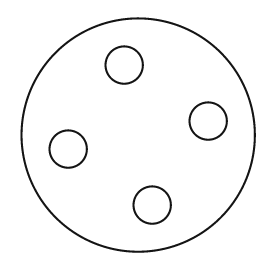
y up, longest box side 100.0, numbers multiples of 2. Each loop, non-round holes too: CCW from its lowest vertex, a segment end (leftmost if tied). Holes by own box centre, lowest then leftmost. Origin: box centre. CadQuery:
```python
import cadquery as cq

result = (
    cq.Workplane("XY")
    .moveTo(0.0, 0.0)
    .circle(50.0)
    .moveTo(6.0, -30.0)
    .circle(8.0)
    .moveTo(-30.0, -6.0)
    .circle(8.0)
    .moveTo(30.0, 6.0)
    .circle(8.0)
    .moveTo(-6.0, 30.0)
    .circle(8.0)
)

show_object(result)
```